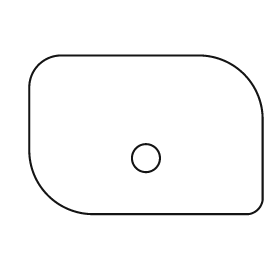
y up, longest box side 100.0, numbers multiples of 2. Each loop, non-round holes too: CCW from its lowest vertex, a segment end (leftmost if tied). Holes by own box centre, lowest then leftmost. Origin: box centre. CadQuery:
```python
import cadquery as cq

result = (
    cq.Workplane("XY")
    .moveTo(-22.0, -34.0)
    .lineTo(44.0, -34.0)
    .threePointArc((48.0, -32.0), (50.0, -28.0))
    .lineTo(50.0, 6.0)
    .threePointArc((42.0, 26.0), (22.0, 34.0))
    .lineTo(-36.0, 34.0)
    .threePointArc((-46.0, 30.0), (-50.0, 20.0))
    .lineTo(-50.0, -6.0)
    .threePointArc((-42.0, -26.0), (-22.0, -34.0))
    .close()
    .moveTo(0.0, -10.0)
    .circle(6.0)
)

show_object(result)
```